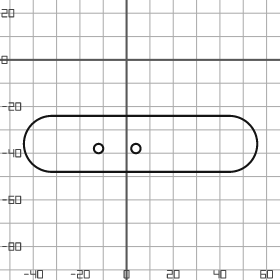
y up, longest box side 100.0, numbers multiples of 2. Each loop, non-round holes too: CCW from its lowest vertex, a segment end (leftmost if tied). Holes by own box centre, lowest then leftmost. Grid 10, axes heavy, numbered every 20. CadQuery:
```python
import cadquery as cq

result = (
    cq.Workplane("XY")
    .moveTo(-32.0, -48.0)
    .lineTo(44.0, -48.0)
    .threePointArc((56.0, -36.0), (44.0, -24.0))
    .lineTo(-32.0, -24.0)
    .threePointArc((-44.0, -36.0), (-32.0, -48.0))
    .close()
    .moveTo(-12.0, -38.0)
    .circle(2.0)
    .moveTo(4.0, -38.0)
    .circle(2.0)
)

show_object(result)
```